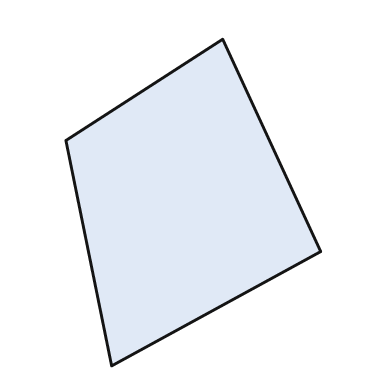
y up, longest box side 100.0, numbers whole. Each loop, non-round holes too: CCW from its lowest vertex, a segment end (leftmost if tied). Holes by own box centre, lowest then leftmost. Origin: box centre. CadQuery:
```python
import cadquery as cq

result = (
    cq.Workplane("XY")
    .moveTo(-25.0, -50.0)
    .lineTo(39.0, -15.0)
    .lineTo(9.0, 50.0)
    .lineTo(-39.0, 19.0)
    .close()
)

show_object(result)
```